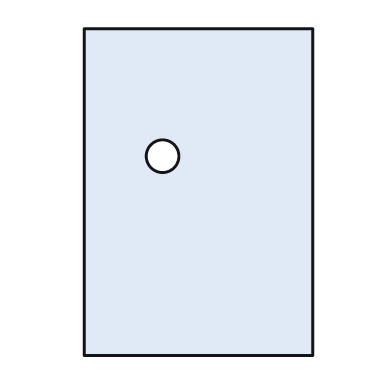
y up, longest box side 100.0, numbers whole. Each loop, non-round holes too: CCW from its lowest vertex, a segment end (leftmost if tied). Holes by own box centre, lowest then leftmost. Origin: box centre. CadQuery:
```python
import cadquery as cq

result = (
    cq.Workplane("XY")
    .moveTo(-35.0, -50.0)
    .lineTo(35.0, -50.0)
    .lineTo(35.0, 50.0)
    .lineTo(-35.0, 50.0)
    .close()
    .moveTo(-11.0, 11.0)
    .circle(5.0)
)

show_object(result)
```